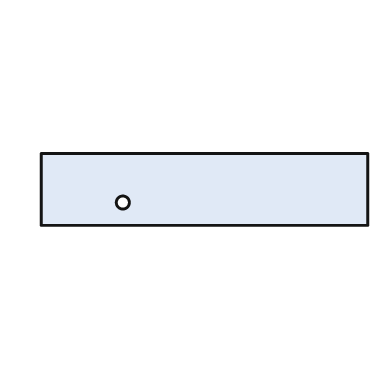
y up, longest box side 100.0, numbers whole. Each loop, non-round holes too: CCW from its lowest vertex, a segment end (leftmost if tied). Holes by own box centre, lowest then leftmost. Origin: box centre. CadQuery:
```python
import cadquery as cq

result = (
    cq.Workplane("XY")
    .moveTo(-50.0, -11.0)
    .lineTo(50.0, -11.0)
    .lineTo(50.0, 11.0)
    .lineTo(-50.0, 11.0)
    .close()
    .moveTo(-25.0, -4.0)
    .circle(2.0)
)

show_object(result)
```